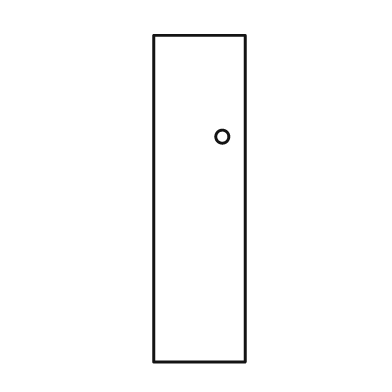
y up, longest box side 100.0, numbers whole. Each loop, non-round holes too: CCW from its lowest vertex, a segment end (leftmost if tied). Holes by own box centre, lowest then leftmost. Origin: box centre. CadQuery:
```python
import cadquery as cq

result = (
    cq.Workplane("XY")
    .moveTo(-14.0, -50.0)
    .lineTo(14.0, -50.0)
    .lineTo(14.0, 50.0)
    .lineTo(-14.0, 50.0)
    .close()
    .moveTo(7.0, 19.0)
    .circle(2.0)
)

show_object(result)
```